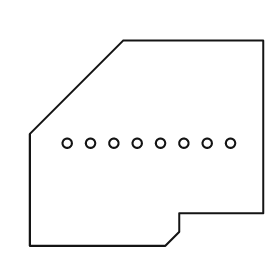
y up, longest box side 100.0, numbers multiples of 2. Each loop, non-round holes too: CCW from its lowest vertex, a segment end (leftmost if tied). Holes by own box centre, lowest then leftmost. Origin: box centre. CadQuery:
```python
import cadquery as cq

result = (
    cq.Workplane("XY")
    .moveTo(-50.0, -44.0)
    .lineTo(8.0, -44.0)
    .lineTo(14.0, -38.0)
    .lineTo(14.0, -30.0)
    .lineTo(50.0, -30.0)
    .lineTo(50.0, 44.0)
    .lineTo(-10.0, 44.0)
    .lineTo(-50.0, 4.0)
    .close()
    .moveTo(-34.0, 0.0)
    .circle(2.0)
    .moveTo(-24.0, 0.0)
    .circle(2.0)
    .moveTo(-14.0, 0.0)
    .circle(2.0)
    .moveTo(-4.0, 0.0)
    .circle(2.0)
    .moveTo(6.0, 0.0)
    .circle(2.0)
    .moveTo(16.0, 0.0)
    .circle(2.0)
    .moveTo(26.0, 0.0)
    .circle(2.0)
    .moveTo(36.0, 0.0)
    .circle(2.0)
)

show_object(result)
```